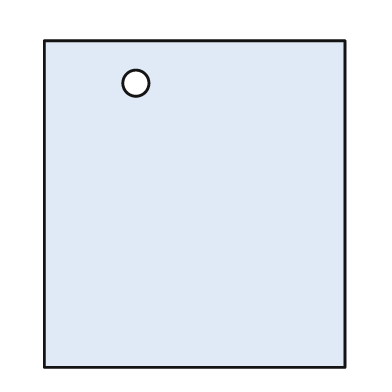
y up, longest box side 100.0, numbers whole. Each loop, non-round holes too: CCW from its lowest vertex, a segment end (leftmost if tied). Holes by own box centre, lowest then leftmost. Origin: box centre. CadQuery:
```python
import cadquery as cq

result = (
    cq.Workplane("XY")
    .moveTo(-46.0, -50.0)
    .lineTo(46.0, -50.0)
    .lineTo(46.0, 50.0)
    .lineTo(-46.0, 50.0)
    .close()
    .moveTo(-18.0, 37.0)
    .circle(4.0)
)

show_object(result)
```